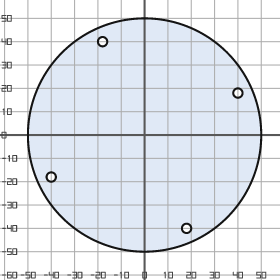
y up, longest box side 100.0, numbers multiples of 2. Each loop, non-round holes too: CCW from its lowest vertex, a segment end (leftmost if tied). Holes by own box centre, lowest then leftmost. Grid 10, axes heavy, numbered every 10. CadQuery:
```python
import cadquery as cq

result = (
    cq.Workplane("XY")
    .moveTo(0.0, 0.0)
    .circle(50.0)
    .moveTo(18.0, -40.0)
    .circle(2.0)
    .moveTo(-40.0, -18.0)
    .circle(2.0)
    .moveTo(40.0, 18.0)
    .circle(2.0)
    .moveTo(-18.0, 40.0)
    .circle(2.0)
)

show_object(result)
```